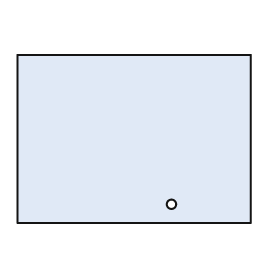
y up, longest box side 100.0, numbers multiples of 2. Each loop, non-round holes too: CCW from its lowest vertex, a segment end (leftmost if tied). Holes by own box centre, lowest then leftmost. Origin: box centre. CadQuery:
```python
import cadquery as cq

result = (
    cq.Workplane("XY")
    .moveTo(-50.0, -36.0)
    .lineTo(50.0, -36.0)
    .lineTo(50.0, 36.0)
    .lineTo(-50.0, 36.0)
    .close()
    .moveTo(16.0, -28.0)
    .circle(2.0)
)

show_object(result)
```